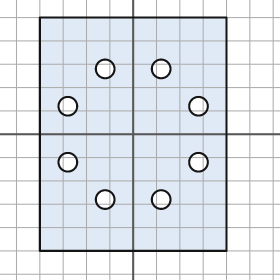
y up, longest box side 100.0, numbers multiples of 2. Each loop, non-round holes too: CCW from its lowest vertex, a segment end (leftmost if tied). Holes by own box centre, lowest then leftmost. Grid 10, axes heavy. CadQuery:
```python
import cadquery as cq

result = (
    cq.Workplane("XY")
    .moveTo(-40.0, -50.0)
    .lineTo(40.0, -50.0)
    .lineTo(40.0, 50.0)
    .lineTo(-40.0, 50.0)
    .close()
    .moveTo(-12.0, -28.0)
    .circle(4.0)
    .moveTo(12.0, -28.0)
    .circle(4.0)
    .moveTo(-28.0, -12.0)
    .circle(4.0)
    .moveTo(28.0, -12.0)
    .circle(4.0)
    .moveTo(-28.0, 12.0)
    .circle(4.0)
    .moveTo(28.0, 12.0)
    .circle(4.0)
    .moveTo(-12.0, 28.0)
    .circle(4.0)
    .moveTo(12.0, 28.0)
    .circle(4.0)
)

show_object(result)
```